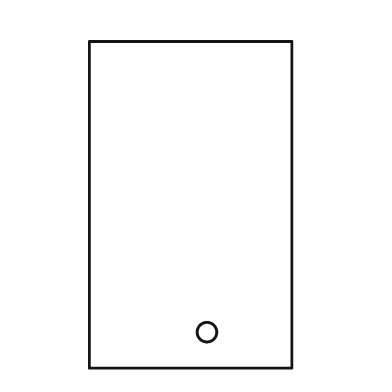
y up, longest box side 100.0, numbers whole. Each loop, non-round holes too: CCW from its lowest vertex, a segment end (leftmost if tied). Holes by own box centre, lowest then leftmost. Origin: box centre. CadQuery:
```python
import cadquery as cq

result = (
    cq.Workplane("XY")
    .moveTo(-31.0, -50.0)
    .lineTo(31.0, -50.0)
    .lineTo(31.0, 50.0)
    .lineTo(-31.0, 50.0)
    .close()
    .moveTo(5.0, -39.0)
    .circle(3.0)
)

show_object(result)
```